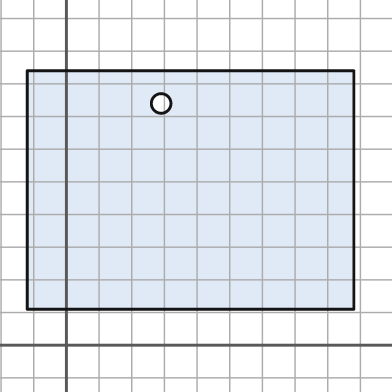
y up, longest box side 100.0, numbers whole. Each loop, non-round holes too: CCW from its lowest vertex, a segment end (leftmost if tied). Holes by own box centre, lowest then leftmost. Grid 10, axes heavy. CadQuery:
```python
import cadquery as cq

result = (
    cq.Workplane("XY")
    .moveTo(-12.0, 11.0)
    .lineTo(88.0, 11.0)
    .lineTo(88.0, 84.0)
    .lineTo(-12.0, 84.0)
    .close()
    .moveTo(29.0, 74.0)
    .circle(3.0)
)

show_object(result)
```